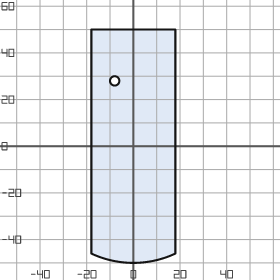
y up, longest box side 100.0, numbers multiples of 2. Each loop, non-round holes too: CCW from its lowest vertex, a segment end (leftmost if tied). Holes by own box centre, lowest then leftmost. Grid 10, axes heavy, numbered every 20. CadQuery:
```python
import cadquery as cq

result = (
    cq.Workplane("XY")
    .moveTo(-18.0, -46.0)
    .threePointArc((0.0, -50.0), (18.0, -46.0))
    .lineTo(18.0, 50.0)
    .lineTo(-18.0, 50.0)
    .close()
    .moveTo(-8.0, 28.0)
    .circle(2.0)
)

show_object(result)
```